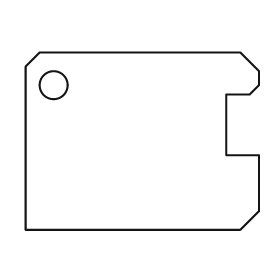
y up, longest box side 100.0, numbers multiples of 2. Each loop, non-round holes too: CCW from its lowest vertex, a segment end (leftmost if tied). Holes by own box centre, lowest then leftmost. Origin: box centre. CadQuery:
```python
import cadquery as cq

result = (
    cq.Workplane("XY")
    .moveTo(-50.0, -38.0)
    .lineTo(42.0, -38.0)
    .lineTo(50.0, -30.0)
    .lineTo(50.0, -6.0)
    .lineTo(36.0, -6.0)
    .lineTo(36.0, 20.0)
    .lineTo(46.0, 20.0)
    .lineTo(50.0, 24.0)
    .lineTo(50.0, 30.0)
    .lineTo(42.0, 38.0)
    .lineTo(-44.0, 38.0)
    .lineTo(-50.0, 32.0)
    .close()
    .moveTo(-38.0, 24.0)
    .circle(6.0)
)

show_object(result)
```